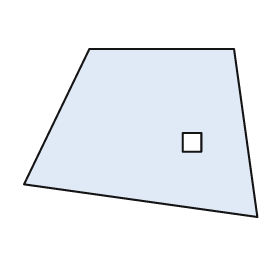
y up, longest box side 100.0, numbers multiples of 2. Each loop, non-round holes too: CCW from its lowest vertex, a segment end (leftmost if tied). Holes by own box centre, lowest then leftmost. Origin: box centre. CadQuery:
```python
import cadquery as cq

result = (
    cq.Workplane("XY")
    .moveTo(50.0, -36.0)
    .lineTo(40.0, 36.0)
    .lineTo(-22.0, 36.0)
    .lineTo(-50.0, -22.0)
    .close()
    .moveTo(18.0, -8.0)
    .lineTo(26.0, -8.0)
    .lineTo(26.0, 0.0)
    .lineTo(18.0, 0.0)
    .close()
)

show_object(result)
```